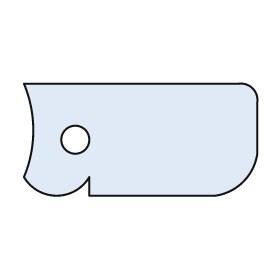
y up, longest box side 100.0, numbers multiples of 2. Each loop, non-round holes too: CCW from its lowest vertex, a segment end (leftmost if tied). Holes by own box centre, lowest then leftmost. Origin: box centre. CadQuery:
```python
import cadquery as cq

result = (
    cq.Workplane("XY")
    .moveTo(-22.0, -24.0)
    .lineTo(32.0, -24.0)
    .threePointArc((44.0, -18.0), (50.0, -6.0))
    .lineTo(50.0, 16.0)
    .threePointArc((48.0, 22.0), (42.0, 24.0))
    .lineTo(-50.0, 24.0)
    .threePointArc((-46.0, 4.0), (-50.0, -16.0))
    .threePointArc((-36.0, -24.0), (-22.0, -16.0))
    .close()
    .moveTo(-28.0, 0.0)
    .circle(6.0)
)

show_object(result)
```